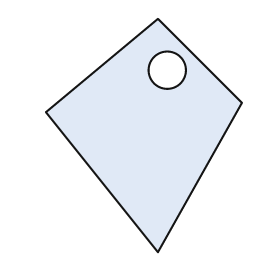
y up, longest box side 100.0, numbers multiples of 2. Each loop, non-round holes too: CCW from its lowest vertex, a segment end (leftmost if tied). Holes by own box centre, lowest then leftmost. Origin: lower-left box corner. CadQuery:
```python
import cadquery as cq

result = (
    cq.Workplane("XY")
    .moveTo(48.0, 0.0)
    .lineTo(84.0, 64.0)
    .lineTo(48.0, 100.0)
    .lineTo(0.0, 60.0)
    .close()
    .moveTo(52.0, 78.0)
    .circle(8.0)
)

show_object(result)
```